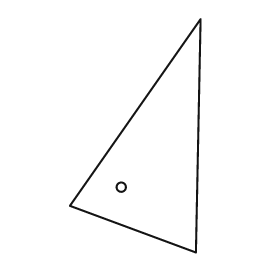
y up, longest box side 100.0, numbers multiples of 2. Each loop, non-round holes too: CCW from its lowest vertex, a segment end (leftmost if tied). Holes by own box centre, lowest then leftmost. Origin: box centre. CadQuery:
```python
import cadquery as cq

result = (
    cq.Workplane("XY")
    .moveTo(26.0, -50.0)
    .lineTo(28.0, 50.0)
    .lineTo(-28.0, -30.0)
    .close()
    .moveTo(-6.0, -22.0)
    .circle(2.0)
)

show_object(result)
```